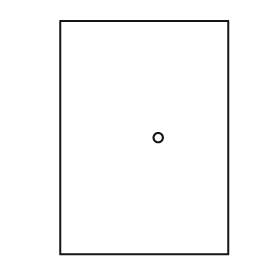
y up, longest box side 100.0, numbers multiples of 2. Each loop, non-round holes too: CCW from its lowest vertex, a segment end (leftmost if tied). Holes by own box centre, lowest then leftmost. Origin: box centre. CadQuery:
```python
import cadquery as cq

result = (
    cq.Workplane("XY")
    .moveTo(-36.0, -50.0)
    .lineTo(36.0, -50.0)
    .lineTo(36.0, 50.0)
    .lineTo(-36.0, 50.0)
    .close()
    .moveTo(6.0, 0.0)
    .circle(2.0)
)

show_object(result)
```